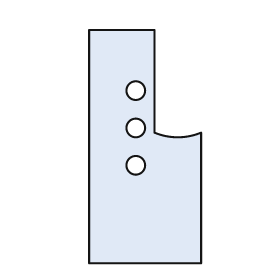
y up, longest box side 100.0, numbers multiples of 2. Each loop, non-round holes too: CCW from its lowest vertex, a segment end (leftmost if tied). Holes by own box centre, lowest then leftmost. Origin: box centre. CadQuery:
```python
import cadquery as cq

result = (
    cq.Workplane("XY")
    .moveTo(-24.0, -50.0)
    .lineTo(24.0, -50.0)
    .lineTo(24.0, 6.0)
    .threePointArc((14.0, 4.0), (4.0, 6.0))
    .lineTo(4.0, 50.0)
    .lineTo(-24.0, 50.0)
    .close()
    .moveTo(-4.0, -8.0)
    .circle(4.0)
    .moveTo(-4.0, 8.0)
    .circle(4.0)
    .moveTo(-4.0, 24.0)
    .circle(4.0)
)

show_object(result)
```